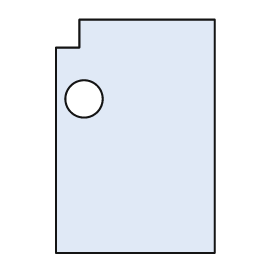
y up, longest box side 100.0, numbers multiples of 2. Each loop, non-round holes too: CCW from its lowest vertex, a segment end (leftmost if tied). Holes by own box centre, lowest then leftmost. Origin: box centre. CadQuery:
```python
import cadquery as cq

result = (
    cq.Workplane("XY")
    .moveTo(-34.0, -50.0)
    .lineTo(34.0, -50.0)
    .lineTo(34.0, 50.0)
    .lineTo(-24.0, 50.0)
    .lineTo(-24.0, 38.0)
    .lineTo(-34.0, 38.0)
    .close()
    .moveTo(-22.0, 16.0)
    .circle(8.0)
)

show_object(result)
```